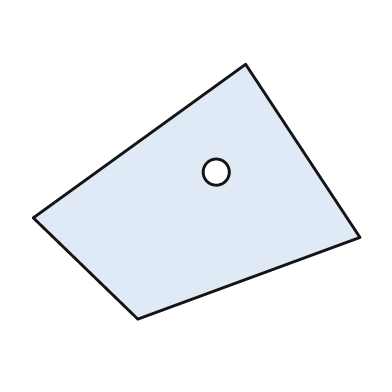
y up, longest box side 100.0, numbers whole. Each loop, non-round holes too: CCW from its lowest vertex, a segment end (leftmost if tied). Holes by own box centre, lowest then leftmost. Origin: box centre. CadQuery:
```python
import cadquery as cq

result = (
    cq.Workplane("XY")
    .moveTo(-18.0, -39.0)
    .lineTo(50.0, -14.0)
    .lineTo(15.0, 39.0)
    .lineTo(-50.0, -8.0)
    .close()
    .moveTo(6.0, 6.0)
    .circle(4.0)
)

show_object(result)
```